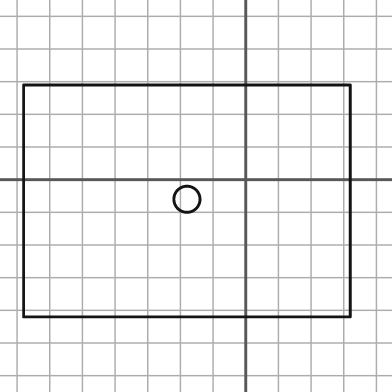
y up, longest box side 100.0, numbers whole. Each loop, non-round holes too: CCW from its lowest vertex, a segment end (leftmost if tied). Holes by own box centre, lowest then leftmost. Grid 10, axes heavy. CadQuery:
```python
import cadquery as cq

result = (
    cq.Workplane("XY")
    .moveTo(-68.0, -42.0)
    .lineTo(32.0, -42.0)
    .lineTo(32.0, 29.0)
    .lineTo(-68.0, 29.0)
    .close()
    .moveTo(-18.0, -6.0)
    .circle(4.0)
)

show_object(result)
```